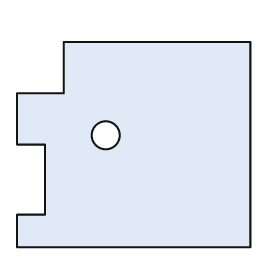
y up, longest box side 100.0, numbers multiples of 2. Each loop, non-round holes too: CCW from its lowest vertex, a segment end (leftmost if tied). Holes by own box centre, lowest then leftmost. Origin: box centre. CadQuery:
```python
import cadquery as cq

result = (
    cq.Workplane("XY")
    .moveTo(-50.0, -44.0)
    .lineTo(50.0, -44.0)
    .lineTo(50.0, 44.0)
    .lineTo(-30.0, 44.0)
    .lineTo(-30.0, 22.0)
    .lineTo(-50.0, 22.0)
    .lineTo(-50.0, 0.0)
    .lineTo(-38.0, 0.0)
    .lineTo(-38.0, -30.0)
    .lineTo(-50.0, -30.0)
    .close()
    .moveTo(-12.0, 4.0)
    .circle(6.0)
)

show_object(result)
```